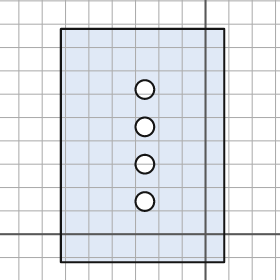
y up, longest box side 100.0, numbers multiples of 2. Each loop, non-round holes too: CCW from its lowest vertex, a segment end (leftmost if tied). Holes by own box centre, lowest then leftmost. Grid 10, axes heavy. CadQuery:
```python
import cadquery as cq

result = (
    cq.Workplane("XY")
    .moveTo(-62.0, -12.0)
    .lineTo(8.0, -12.0)
    .lineTo(8.0, 88.0)
    .lineTo(-62.0, 88.0)
    .close()
    .moveTo(-26.0, 14.0)
    .circle(4.0)
    .moveTo(-26.0, 30.0)
    .circle(4.0)
    .moveTo(-26.0, 46.0)
    .circle(4.0)
    .moveTo(-26.0, 62.0)
    .circle(4.0)
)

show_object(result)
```